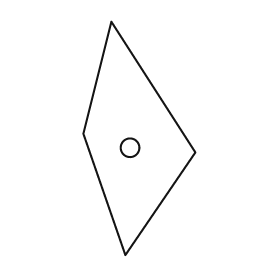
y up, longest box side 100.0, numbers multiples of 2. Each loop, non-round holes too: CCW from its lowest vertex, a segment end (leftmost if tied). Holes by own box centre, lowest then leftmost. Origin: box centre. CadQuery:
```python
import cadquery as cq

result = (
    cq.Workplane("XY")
    .moveTo(-6.0, -50.0)
    .lineTo(24.0, -6.0)
    .lineTo(-12.0, 50.0)
    .lineTo(-24.0, 2.0)
    .close()
    .moveTo(-4.0, -4.0)
    .circle(4.0)
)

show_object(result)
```